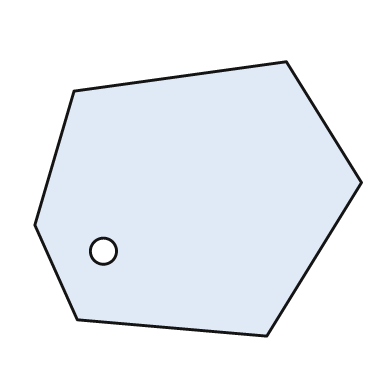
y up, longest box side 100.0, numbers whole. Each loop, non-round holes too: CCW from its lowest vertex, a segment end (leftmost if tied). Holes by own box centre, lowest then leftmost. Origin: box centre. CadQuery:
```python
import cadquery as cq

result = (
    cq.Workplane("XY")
    .moveTo(21.0, -42.0)
    .lineTo(50.0, 5.0)
    .lineTo(27.0, 42.0)
    .lineTo(-38.0, 33.0)
    .lineTo(-50.0, -8.0)
    .lineTo(-37.0, -37.0)
    .close()
    .moveTo(-29.0, -16.0)
    .circle(4.0)
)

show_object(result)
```